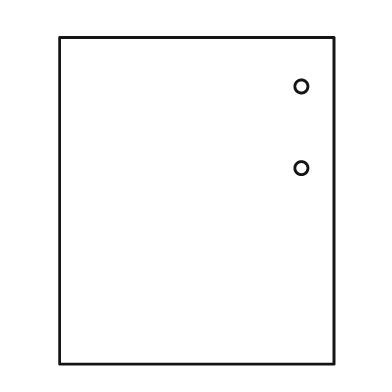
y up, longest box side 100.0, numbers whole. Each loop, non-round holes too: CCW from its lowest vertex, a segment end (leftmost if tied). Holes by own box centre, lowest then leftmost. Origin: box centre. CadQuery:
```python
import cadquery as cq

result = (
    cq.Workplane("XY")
    .moveTo(-42.0, -50.0)
    .lineTo(42.0, -50.0)
    .lineTo(42.0, 50.0)
    .lineTo(-42.0, 50.0)
    .close()
    .moveTo(32.0, 10.0)
    .circle(2.0)
    .moveTo(32.0, 35.0)
    .circle(2.0)
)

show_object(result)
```